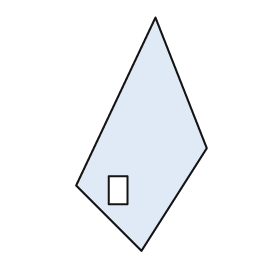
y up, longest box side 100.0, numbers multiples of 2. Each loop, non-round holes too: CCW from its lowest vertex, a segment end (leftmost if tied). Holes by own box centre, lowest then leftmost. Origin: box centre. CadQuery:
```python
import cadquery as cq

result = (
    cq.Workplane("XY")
    .moveTo(0.0, -50.0)
    .lineTo(28.0, -6.0)
    .lineTo(6.0, 50.0)
    .lineTo(-28.0, -22.0)
    .close()
    .moveTo(-14.0, -30.0)
    .lineTo(-6.0, -30.0)
    .lineTo(-6.0, -18.0)
    .lineTo(-14.0, -18.0)
    .close()
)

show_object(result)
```